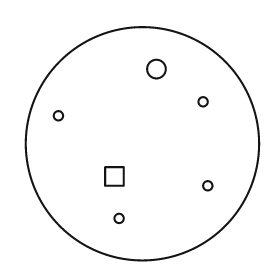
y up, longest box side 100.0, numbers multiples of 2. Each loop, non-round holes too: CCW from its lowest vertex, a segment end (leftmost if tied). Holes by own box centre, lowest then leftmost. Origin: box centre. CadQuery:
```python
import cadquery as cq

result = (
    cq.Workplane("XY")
    .moveTo(0.0, 0.0)
    .circle(50.0)
    .moveTo(-10.0, -32.0)
    .circle(2.0)
    .moveTo(28.0, -18.0)
    .circle(2.0)
    .moveTo(-16.0, -18.0)
    .lineTo(-8.0, -18.0)
    .lineTo(-8.0, -10.0)
    .lineTo(-16.0, -10.0)
    .close()
    .moveTo(-36.0, 12.0)
    .circle(2.0)
    .moveTo(26.0, 18.0)
    .circle(2.0)
    .moveTo(6.0, 32.0)
    .circle(4.0)
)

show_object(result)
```